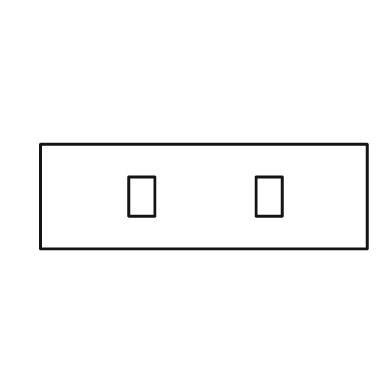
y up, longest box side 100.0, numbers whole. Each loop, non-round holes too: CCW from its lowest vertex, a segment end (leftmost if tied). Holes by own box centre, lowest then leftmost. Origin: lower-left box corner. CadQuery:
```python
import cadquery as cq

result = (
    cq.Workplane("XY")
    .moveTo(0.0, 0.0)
    .lineTo(100.0, 0.0)
    .lineTo(100.0, 32.0)
    .lineTo(0.0, 32.0)
    .close()
    .moveTo(27.0, 10.0)
    .lineTo(35.0, 10.0)
    .lineTo(35.0, 22.0)
    .lineTo(27.0, 22.0)
    .close()
    .moveTo(66.0, 10.0)
    .lineTo(74.0, 10.0)
    .lineTo(74.0, 22.0)
    .lineTo(66.0, 22.0)
    .close()
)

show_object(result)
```